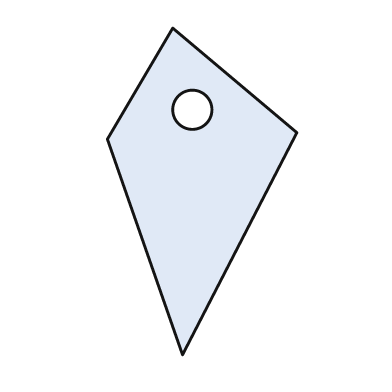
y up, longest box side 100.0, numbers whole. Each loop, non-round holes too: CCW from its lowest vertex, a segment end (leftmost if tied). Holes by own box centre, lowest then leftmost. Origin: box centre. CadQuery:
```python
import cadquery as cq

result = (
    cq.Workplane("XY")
    .moveTo(-6.0, -50.0)
    .lineTo(29.0, 18.0)
    .lineTo(-9.0, 50.0)
    .lineTo(-29.0, 16.0)
    .close()
    .moveTo(-3.0, 25.0)
    .circle(6.0)
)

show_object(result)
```